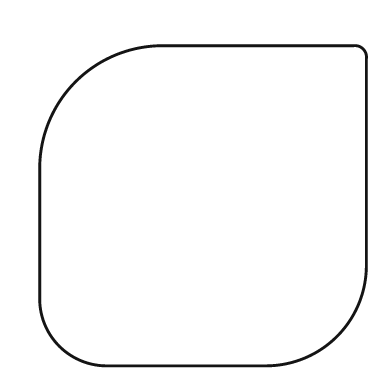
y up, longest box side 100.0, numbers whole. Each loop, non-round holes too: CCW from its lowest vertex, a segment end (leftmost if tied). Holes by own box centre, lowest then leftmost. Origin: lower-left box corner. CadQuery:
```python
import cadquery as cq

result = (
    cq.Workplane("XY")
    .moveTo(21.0, 0.0)
    .lineTo(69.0, 0.0)
    .threePointArc((91.0, 9.0), (100.0, 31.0))
    .lineTo(100.0, 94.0)
    .threePointArc((99.0, 97.0), (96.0, 98.0))
    .lineTo(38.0, 98.0)
    .threePointArc((11.0, 87.0), (0.0, 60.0))
    .lineTo(0.0, 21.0)
    .threePointArc((6.0, 6.0), (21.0, 0.0))
    .close()
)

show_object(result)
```